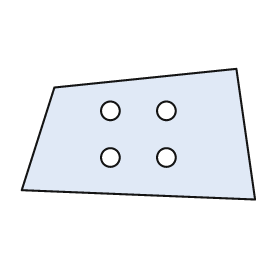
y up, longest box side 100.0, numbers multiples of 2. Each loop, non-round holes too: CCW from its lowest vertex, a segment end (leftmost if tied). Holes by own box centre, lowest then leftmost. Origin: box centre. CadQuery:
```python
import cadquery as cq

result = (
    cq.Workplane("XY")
    .moveTo(50.0, -28.0)
    .lineTo(42.0, 28.0)
    .lineTo(-36.0, 20.0)
    .lineTo(-50.0, -24.0)
    .close()
    .moveTo(-12.0, -10.0)
    .circle(4.0)
    .moveTo(12.0, -10.0)
    .circle(4.0)
    .moveTo(-12.0, 10.0)
    .circle(4.0)
    .moveTo(12.0, 10.0)
    .circle(4.0)
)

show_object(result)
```